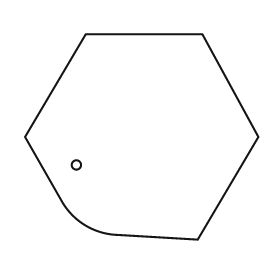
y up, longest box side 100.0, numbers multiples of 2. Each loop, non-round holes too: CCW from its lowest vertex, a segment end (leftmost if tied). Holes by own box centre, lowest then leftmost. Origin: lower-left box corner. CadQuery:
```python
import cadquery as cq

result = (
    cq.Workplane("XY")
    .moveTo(74.0, 0.0)
    .lineTo(100.0, 44.0)
    .lineTo(76.0, 88.0)
    .lineTo(26.0, 88.0)
    .lineTo(0.0, 44.0)
    .lineTo(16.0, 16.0)
    .threePointArc((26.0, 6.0), (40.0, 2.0))
    .close()
    .moveTo(22.0, 32.0)
    .circle(2.0)
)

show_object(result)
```